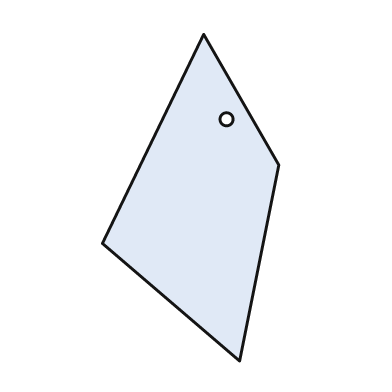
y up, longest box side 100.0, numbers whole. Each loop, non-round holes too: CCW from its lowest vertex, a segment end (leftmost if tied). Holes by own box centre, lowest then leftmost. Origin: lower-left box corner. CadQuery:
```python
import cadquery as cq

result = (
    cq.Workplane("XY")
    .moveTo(42.0, 0.0)
    .lineTo(54.0, 60.0)
    .lineTo(31.0, 100.0)
    .lineTo(0.0, 36.0)
    .close()
    .moveTo(38.0, 74.0)
    .circle(2.0)
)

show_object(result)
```